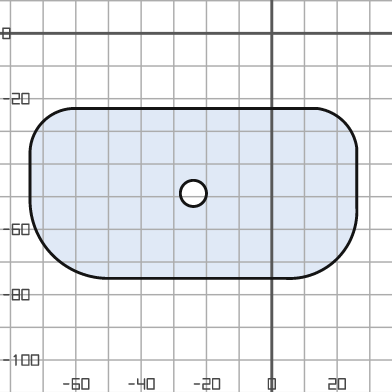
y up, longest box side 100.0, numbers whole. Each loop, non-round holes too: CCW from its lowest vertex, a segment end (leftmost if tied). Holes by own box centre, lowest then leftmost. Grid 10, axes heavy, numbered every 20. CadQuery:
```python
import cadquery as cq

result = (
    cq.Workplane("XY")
    .moveTo(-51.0, -75.0)
    .lineTo(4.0, -75.0)
    .threePointArc((20.0, -69.0), (26.0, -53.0))
    .lineTo(26.0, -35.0)
    .threePointArc((22.0, -27.0), (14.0, -23.0))
    .lineTo(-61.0, -23.0)
    .threePointArc((-70.0, -27.0), (-74.0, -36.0))
    .lineTo(-74.0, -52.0)
    .threePointArc((-67.0, -68.0), (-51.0, -75.0))
    .close()
    .moveTo(-24.0, -49.0)
    .circle(4.0)
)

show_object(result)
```